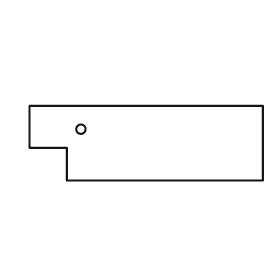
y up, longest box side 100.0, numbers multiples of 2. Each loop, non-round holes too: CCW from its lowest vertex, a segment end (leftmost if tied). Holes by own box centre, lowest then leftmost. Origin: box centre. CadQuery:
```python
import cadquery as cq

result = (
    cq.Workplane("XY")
    .moveTo(-34.0, -16.0)
    .lineTo(50.0, -16.0)
    .lineTo(50.0, 16.0)
    .lineTo(-50.0, 16.0)
    .lineTo(-50.0, -2.0)
    .lineTo(-34.0, -2.0)
    .close()
    .moveTo(-28.0, 6.0)
    .circle(2.0)
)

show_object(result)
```